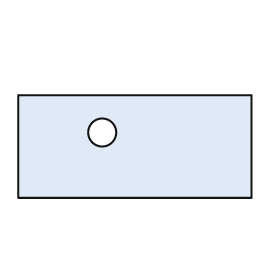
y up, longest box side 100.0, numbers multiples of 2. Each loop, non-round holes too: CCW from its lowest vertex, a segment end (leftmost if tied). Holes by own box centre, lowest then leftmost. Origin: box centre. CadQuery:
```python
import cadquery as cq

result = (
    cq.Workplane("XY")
    .moveTo(-50.0, -22.0)
    .lineTo(50.0, -22.0)
    .lineTo(50.0, 22.0)
    .lineTo(-50.0, 22.0)
    .close()
    .moveTo(-14.0, 6.0)
    .circle(6.0)
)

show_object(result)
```